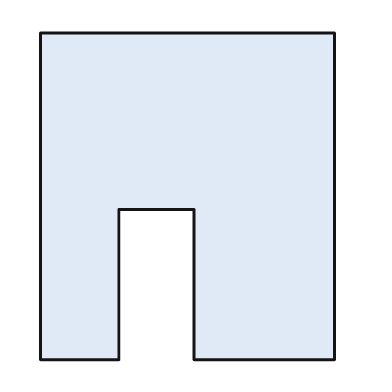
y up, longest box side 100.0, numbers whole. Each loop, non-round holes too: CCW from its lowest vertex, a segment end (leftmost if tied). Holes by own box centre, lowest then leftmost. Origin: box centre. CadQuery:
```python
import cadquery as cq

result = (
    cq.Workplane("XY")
    .moveTo(-45.0, -50.0)
    .lineTo(-21.0, -50.0)
    .lineTo(-21.0, -4.0)
    .lineTo(2.0, -4.0)
    .lineTo(2.0, -50.0)
    .lineTo(45.0, -50.0)
    .lineTo(45.0, 50.0)
    .lineTo(-45.0, 50.0)
    .close()
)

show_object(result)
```